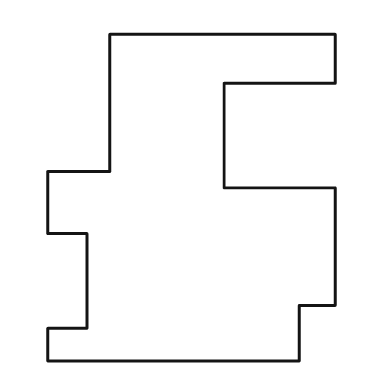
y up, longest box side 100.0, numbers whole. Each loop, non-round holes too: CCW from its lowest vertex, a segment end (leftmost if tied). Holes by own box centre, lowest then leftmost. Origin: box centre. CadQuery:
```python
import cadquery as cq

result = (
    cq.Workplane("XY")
    .moveTo(-44.0, -50.0)
    .lineTo(33.0, -50.0)
    .lineTo(33.0, -33.0)
    .lineTo(44.0, -33.0)
    .lineTo(44.0, 3.0)
    .lineTo(10.0, 3.0)
    .lineTo(10.0, 35.0)
    .lineTo(44.0, 35.0)
    .lineTo(44.0, 50.0)
    .lineTo(-25.0, 50.0)
    .lineTo(-25.0, 8.0)
    .lineTo(-44.0, 8.0)
    .lineTo(-44.0, -11.0)
    .lineTo(-32.0, -11.0)
    .lineTo(-32.0, -40.0)
    .lineTo(-44.0, -40.0)
    .close()
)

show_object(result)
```